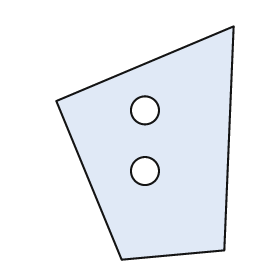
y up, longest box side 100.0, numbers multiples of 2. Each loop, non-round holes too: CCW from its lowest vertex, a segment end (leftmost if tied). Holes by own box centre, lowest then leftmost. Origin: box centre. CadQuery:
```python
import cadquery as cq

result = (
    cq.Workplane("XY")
    .moveTo(-10.0, -50.0)
    .lineTo(34.0, -46.0)
    .lineTo(38.0, 50.0)
    .lineTo(-38.0, 18.0)
    .close()
    .moveTo(0.0, -12.0)
    .circle(6.0)
    .moveTo(0.0, 14.0)
    .circle(6.0)
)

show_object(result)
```